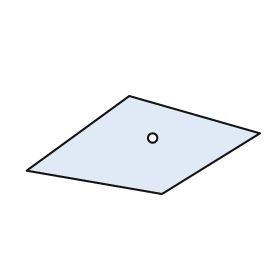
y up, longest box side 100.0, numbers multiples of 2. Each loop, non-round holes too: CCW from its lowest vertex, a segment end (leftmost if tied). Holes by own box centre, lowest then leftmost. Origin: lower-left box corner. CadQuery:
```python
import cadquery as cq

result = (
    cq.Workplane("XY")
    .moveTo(58.0, 0.0)
    .lineTo(100.0, 26.0)
    .lineTo(44.0, 42.0)
    .lineTo(0.0, 10.0)
    .close()
    .moveTo(54.0, 24.0)
    .circle(2.0)
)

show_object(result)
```